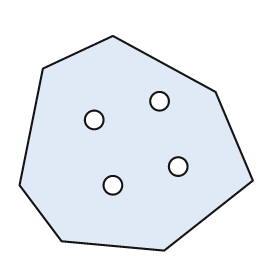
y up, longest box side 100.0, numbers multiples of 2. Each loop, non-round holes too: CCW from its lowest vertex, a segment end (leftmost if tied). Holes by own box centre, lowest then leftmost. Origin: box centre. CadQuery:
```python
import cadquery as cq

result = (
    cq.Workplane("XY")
    .moveTo(12.0, -46.0)
    .lineTo(50.0, -16.0)
    .lineTo(34.0, 22.0)
    .lineTo(-10.0, 46.0)
    .lineTo(-40.0, 32.0)
    .lineTo(-50.0, -18.0)
    .lineTo(-32.0, -42.0)
    .close()
    .moveTo(-10.0, -18.0)
    .circle(4.0)
    .moveTo(18.0, -10.0)
    .circle(4.0)
    .moveTo(-18.0, 10.0)
    .circle(4.0)
    .moveTo(10.0, 18.0)
    .circle(4.0)
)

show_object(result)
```